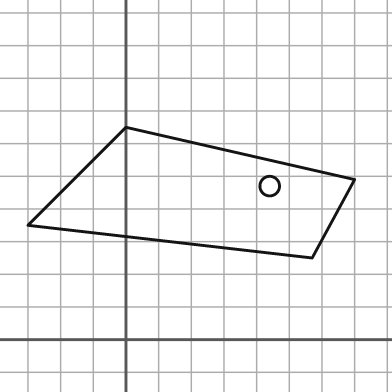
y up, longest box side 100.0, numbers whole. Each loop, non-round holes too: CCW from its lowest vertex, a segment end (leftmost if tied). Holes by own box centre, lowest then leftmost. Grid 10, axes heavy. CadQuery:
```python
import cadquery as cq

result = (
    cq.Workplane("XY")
    .moveTo(57.0, 25.0)
    .lineTo(70.0, 49.0)
    .lineTo(0.0, 65.0)
    .lineTo(-30.0, 35.0)
    .close()
    .moveTo(44.0, 47.0)
    .circle(3.0)
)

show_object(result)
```